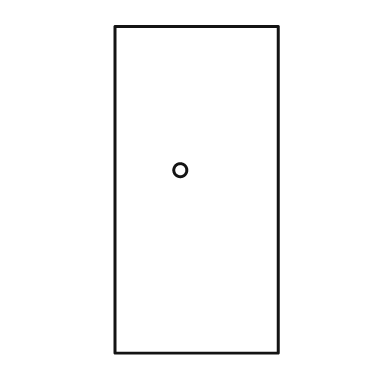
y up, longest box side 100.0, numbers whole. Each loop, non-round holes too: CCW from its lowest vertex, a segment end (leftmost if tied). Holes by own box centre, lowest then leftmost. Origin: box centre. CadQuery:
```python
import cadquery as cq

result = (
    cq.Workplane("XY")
    .moveTo(-25.0, -50.0)
    .lineTo(25.0, -50.0)
    .lineTo(25.0, 50.0)
    .lineTo(-25.0, 50.0)
    .close()
    .moveTo(-5.0, 6.0)
    .circle(2.0)
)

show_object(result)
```